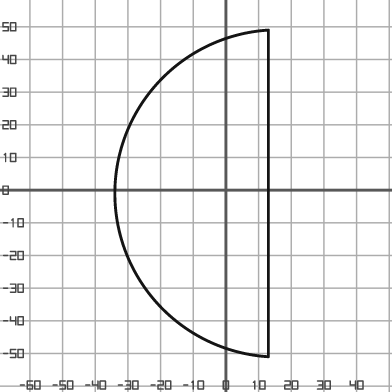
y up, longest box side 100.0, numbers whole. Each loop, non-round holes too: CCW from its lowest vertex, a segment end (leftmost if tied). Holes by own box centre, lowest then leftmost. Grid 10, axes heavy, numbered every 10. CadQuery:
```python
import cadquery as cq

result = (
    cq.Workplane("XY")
    .moveTo(13.0, -51.0)
    .lineTo(13.0, 49.0)
    .threePointArc((-34.0, -1.0), (13.0, -51.0))
    .close()
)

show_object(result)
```